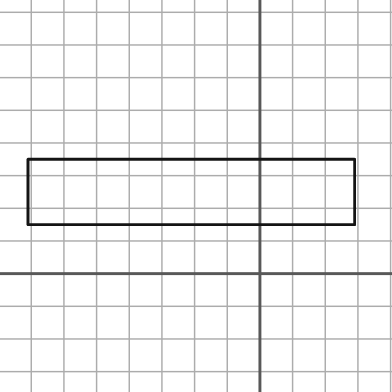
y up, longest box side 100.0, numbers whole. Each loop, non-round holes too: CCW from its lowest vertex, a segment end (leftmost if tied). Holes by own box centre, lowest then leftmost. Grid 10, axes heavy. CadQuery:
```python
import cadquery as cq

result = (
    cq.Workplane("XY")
    .moveTo(-71.0, 15.0)
    .lineTo(29.0, 15.0)
    .lineTo(29.0, 35.0)
    .lineTo(-71.0, 35.0)
    .close()
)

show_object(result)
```